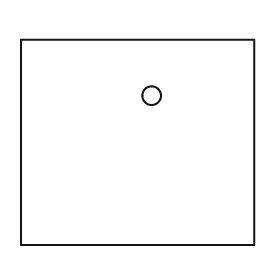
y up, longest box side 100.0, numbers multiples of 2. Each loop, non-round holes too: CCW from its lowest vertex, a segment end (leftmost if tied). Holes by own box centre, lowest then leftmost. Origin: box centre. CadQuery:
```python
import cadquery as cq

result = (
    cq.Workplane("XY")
    .moveTo(-50.0, -44.0)
    .lineTo(50.0, -44.0)
    .lineTo(50.0, 44.0)
    .lineTo(-50.0, 44.0)
    .close()
    .moveTo(6.0, 20.0)
    .circle(4.0)
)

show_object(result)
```